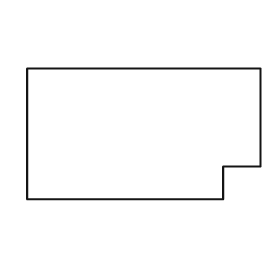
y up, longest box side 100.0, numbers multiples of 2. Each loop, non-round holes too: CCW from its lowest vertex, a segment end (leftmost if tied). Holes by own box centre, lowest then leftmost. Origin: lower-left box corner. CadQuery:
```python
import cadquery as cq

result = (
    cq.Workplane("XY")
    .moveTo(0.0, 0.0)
    .lineTo(84.0, 0.0)
    .lineTo(84.0, 14.0)
    .lineTo(100.0, 14.0)
    .lineTo(100.0, 56.0)
    .lineTo(0.0, 56.0)
    .close()
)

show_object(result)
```